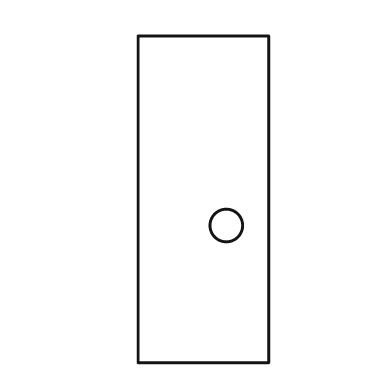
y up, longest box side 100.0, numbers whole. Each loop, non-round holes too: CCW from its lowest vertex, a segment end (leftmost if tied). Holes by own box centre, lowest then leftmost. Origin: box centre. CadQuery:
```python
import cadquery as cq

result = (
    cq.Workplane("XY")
    .moveTo(-20.0, -50.0)
    .lineTo(20.0, -50.0)
    .lineTo(20.0, 50.0)
    .lineTo(-20.0, 50.0)
    .close()
    .moveTo(7.0, -8.0)
    .circle(5.0)
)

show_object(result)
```